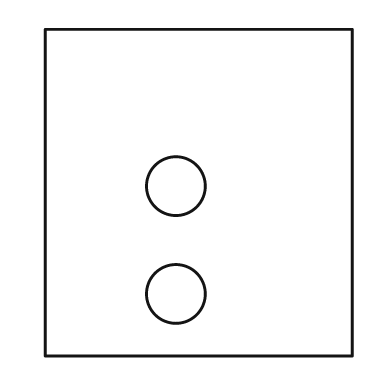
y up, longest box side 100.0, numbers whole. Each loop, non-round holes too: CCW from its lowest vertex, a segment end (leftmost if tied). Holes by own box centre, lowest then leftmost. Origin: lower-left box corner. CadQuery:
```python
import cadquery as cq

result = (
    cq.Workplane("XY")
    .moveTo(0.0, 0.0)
    .lineTo(94.0, 0.0)
    .lineTo(94.0, 100.0)
    .lineTo(0.0, 100.0)
    .close()
    .moveTo(40.0, 19.0)
    .circle(9.0)
    .moveTo(40.0, 52.0)
    .circle(9.0)
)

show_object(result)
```